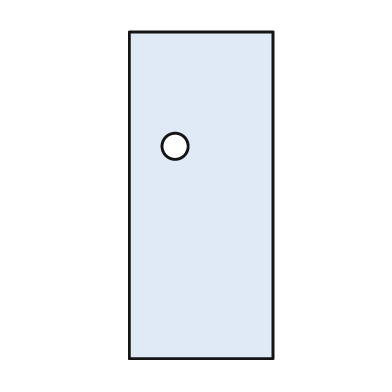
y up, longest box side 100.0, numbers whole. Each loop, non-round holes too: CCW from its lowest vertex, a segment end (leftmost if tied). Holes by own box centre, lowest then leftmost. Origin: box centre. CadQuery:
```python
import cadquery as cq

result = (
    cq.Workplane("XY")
    .moveTo(-22.0, -50.0)
    .lineTo(22.0, -50.0)
    .lineTo(22.0, 50.0)
    .lineTo(-22.0, 50.0)
    .close()
    .moveTo(-8.0, 15.0)
    .circle(4.0)
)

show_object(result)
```